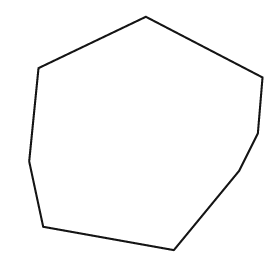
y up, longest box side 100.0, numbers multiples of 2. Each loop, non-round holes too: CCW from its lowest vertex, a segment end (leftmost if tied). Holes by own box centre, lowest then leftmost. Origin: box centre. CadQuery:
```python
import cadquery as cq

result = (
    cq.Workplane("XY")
    .moveTo(12.0, -50.0)
    .lineTo(40.0, -16.0)
    .lineTo(48.0, 0.0)
    .lineTo(50.0, 24.0)
    .lineTo(0.0, 50.0)
    .lineTo(-46.0, 28.0)
    .lineTo(-50.0, -12.0)
    .lineTo(-44.0, -40.0)
    .close()
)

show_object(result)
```